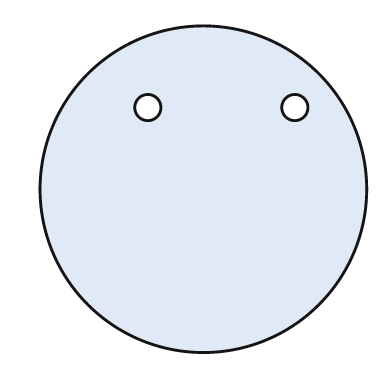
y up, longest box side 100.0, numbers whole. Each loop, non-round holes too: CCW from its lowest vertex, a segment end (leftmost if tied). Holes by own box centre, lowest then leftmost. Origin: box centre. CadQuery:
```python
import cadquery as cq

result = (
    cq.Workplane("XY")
    .moveTo(0.0, 0.0)
    .circle(50.0)
    .moveTo(-17.0, 25.0)
    .circle(4.0)
    .moveTo(28.0, 25.0)
    .circle(4.0)
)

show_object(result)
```